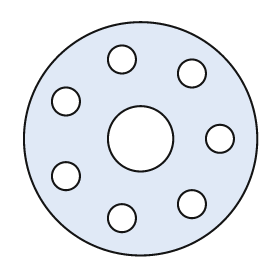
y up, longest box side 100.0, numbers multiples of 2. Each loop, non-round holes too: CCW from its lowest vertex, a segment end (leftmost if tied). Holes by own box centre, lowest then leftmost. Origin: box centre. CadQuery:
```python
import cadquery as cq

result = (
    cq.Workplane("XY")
    .moveTo(0.0, 0.0)
    .circle(50.0)
    .moveTo(-8.0, -34.0)
    .circle(6.0)
    .moveTo(22.0, -28.0)
    .circle(6.0)
    .moveTo(-32.0, -16.0)
    .circle(6.0)
    .moveTo(0.0, 0.0)
    .circle(14.0)
    .moveTo(34.0, 0.0)
    .circle(6.0)
    .moveTo(-32.0, 16.0)
    .circle(6.0)
    .moveTo(22.0, 28.0)
    .circle(6.0)
    .moveTo(-8.0, 34.0)
    .circle(6.0)
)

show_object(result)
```